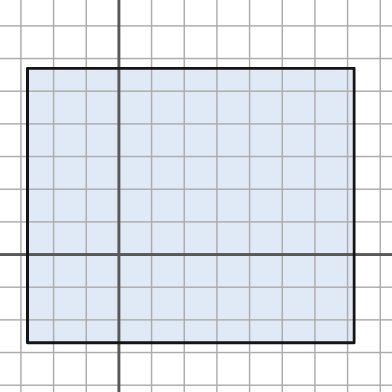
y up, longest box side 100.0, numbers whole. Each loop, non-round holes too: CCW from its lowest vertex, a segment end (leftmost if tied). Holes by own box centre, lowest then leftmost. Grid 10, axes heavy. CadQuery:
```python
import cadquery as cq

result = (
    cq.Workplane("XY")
    .moveTo(-28.0, -27.0)
    .lineTo(72.0, -27.0)
    .lineTo(72.0, 57.0)
    .lineTo(-28.0, 57.0)
    .close()
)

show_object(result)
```